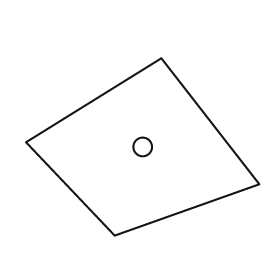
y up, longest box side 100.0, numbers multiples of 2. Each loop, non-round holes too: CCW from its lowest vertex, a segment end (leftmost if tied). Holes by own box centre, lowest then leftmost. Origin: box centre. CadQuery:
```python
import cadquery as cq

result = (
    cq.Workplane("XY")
    .moveTo(-12.0, -38.0)
    .lineTo(50.0, -16.0)
    .lineTo(8.0, 38.0)
    .lineTo(-50.0, 2.0)
    .close()
    .moveTo(0.0, 0.0)
    .circle(4.0)
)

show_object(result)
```